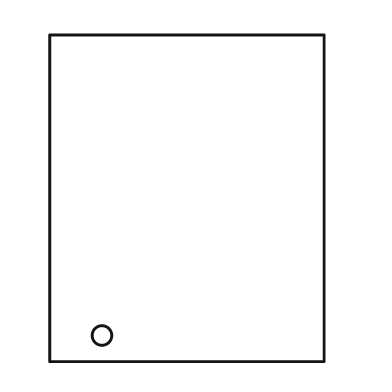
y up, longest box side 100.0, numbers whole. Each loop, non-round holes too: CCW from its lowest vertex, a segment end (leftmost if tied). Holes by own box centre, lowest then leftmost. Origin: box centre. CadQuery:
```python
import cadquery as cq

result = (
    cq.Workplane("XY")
    .moveTo(-42.0, -50.0)
    .lineTo(42.0, -50.0)
    .lineTo(42.0, 50.0)
    .lineTo(-42.0, 50.0)
    .close()
    .moveTo(-26.0, -42.0)
    .circle(3.0)
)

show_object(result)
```